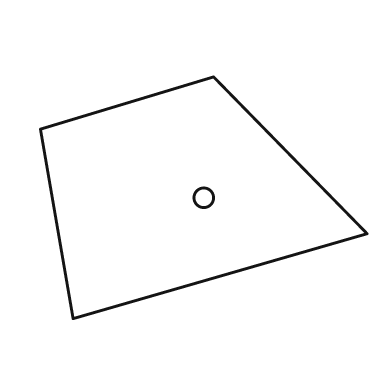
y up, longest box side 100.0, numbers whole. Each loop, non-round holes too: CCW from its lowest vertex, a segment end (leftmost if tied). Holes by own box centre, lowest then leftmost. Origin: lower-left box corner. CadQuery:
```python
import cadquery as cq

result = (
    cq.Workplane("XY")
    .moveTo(10.0, 0.0)
    .lineTo(100.0, 26.0)
    .lineTo(53.0, 74.0)
    .lineTo(0.0, 58.0)
    .close()
    .moveTo(50.0, 37.0)
    .circle(3.0)
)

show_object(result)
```